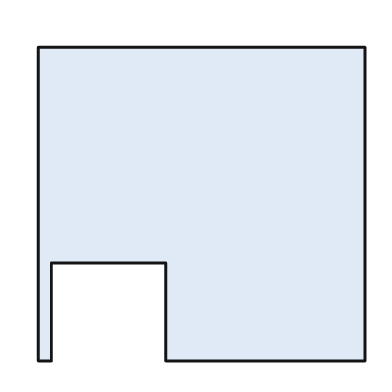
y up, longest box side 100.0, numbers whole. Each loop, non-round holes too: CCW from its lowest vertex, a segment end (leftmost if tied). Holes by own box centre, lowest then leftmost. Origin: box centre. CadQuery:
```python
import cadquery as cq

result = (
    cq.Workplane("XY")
    .moveTo(-50.0, -48.0)
    .lineTo(-46.0, -48.0)
    .lineTo(-46.0, -18.0)
    .lineTo(-11.0, -18.0)
    .lineTo(-11.0, -48.0)
    .lineTo(50.0, -48.0)
    .lineTo(50.0, 48.0)
    .lineTo(-50.0, 48.0)
    .close()
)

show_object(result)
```